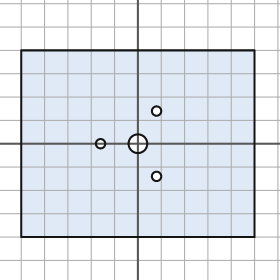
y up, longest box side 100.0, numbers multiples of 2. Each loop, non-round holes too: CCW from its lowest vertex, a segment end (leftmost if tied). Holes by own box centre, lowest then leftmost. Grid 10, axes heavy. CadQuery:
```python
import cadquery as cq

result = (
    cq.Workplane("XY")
    .moveTo(-50.0, -40.0)
    .lineTo(50.0, -40.0)
    .lineTo(50.0, 40.0)
    .lineTo(-50.0, 40.0)
    .close()
    .moveTo(8.0, -14.0)
    .circle(2.0)
    .moveTo(-16.0, 0.0)
    .circle(2.0)
    .moveTo(0.0, 0.0)
    .circle(4.0)
    .moveTo(8.0, 14.0)
    .circle(2.0)
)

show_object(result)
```